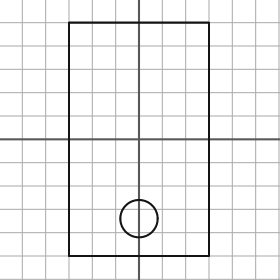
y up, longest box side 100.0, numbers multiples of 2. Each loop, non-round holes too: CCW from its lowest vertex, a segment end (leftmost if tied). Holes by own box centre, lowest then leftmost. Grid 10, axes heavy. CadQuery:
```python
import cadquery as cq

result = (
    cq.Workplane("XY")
    .moveTo(-30.0, -50.0)
    .lineTo(30.0, -50.0)
    .lineTo(30.0, 50.0)
    .lineTo(-30.0, 50.0)
    .close()
    .moveTo(0.0, -34.0)
    .circle(8.0)
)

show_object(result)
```